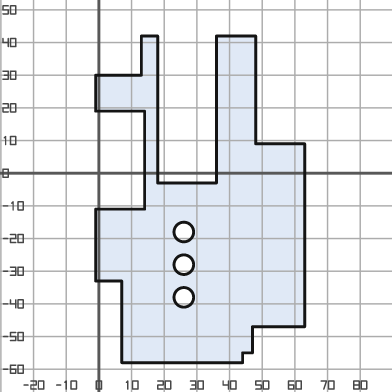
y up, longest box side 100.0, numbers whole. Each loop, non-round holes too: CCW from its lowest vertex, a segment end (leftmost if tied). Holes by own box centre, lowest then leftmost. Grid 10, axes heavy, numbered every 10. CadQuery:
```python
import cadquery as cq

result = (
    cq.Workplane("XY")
    .moveTo(7.0, -58.0)
    .lineTo(44.0, -58.0)
    .lineTo(44.0, -55.0)
    .lineTo(47.0, -55.0)
    .lineTo(47.0, -47.0)
    .lineTo(63.0, -47.0)
    .lineTo(63.0, 9.0)
    .lineTo(48.0, 9.0)
    .lineTo(48.0, 42.0)
    .lineTo(36.0, 42.0)
    .lineTo(36.0, -3.0)
    .lineTo(18.0, -3.0)
    .lineTo(18.0, 42.0)
    .lineTo(13.0, 42.0)
    .lineTo(13.0, 30.0)
    .lineTo(-1.0, 30.0)
    .lineTo(-1.0, 19.0)
    .lineTo(14.0, 19.0)
    .lineTo(14.0, -11.0)
    .lineTo(-1.0, -11.0)
    .lineTo(-1.0, -33.0)
    .lineTo(7.0, -33.0)
    .close()
    .moveTo(26.0, -38.0)
    .circle(3.0)
    .moveTo(26.0, -28.0)
    .circle(3.0)
    .moveTo(26.0, -18.0)
    .circle(3.0)
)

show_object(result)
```